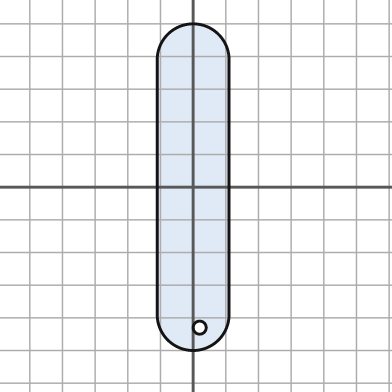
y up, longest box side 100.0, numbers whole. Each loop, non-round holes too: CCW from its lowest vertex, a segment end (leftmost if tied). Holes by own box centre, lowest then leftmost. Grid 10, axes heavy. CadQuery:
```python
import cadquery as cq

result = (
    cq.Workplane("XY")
    .moveTo(-11.0, -39.0)
    .threePointArc((0.0, -50.0), (11.0, -39.0))
    .lineTo(11.0, 39.0)
    .threePointArc((0.0, 50.0), (-11.0, 39.0))
    .close()
    .moveTo(2.0, -43.0)
    .circle(2.0)
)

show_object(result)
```